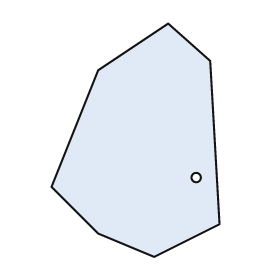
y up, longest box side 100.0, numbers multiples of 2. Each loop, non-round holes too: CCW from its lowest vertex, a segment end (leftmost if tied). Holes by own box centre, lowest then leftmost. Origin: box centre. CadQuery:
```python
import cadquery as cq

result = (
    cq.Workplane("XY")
    .moveTo(8.0, -50.0)
    .lineTo(36.0, -36.0)
    .lineTo(32.0, 34.0)
    .lineTo(14.0, 50.0)
    .lineTo(-16.0, 30.0)
    .lineTo(-36.0, -20.0)
    .lineTo(-16.0, -40.0)
    .close()
    .moveTo(26.0, -16.0)
    .circle(2.0)
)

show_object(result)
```